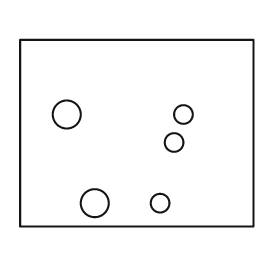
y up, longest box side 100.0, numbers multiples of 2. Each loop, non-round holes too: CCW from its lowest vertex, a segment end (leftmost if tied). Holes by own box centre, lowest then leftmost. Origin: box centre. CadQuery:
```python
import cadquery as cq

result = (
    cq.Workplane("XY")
    .moveTo(-50.0, -40.0)
    .lineTo(50.0, -40.0)
    .lineTo(50.0, 40.0)
    .lineTo(-50.0, 40.0)
    .close()
    .moveTo(-18.0, -30.0)
    .circle(6.0)
    .moveTo(10.0, -30.0)
    .circle(4.0)
    .moveTo(16.0, -4.0)
    .circle(4.0)
    .moveTo(-30.0, 8.0)
    .circle(6.0)
    .moveTo(20.0, 8.0)
    .circle(4.0)
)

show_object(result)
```